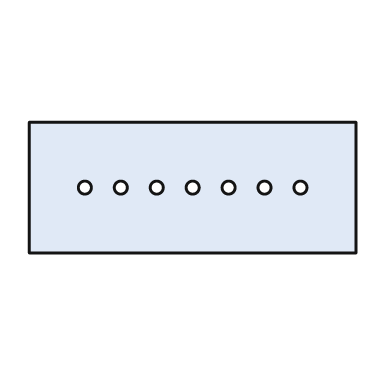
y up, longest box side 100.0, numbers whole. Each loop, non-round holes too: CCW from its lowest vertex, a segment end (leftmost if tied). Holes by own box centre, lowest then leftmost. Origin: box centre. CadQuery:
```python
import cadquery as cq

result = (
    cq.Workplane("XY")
    .moveTo(-50.0, -20.0)
    .lineTo(50.0, -20.0)
    .lineTo(50.0, 20.0)
    .lineTo(-50.0, 20.0)
    .close()
    .moveTo(-33.0, 0.0)
    .circle(2.0)
    .moveTo(-22.0, 0.0)
    .circle(2.0)
    .moveTo(-11.0, 0.0)
    .circle(2.0)
    .moveTo(0.0, 0.0)
    .circle(2.0)
    .moveTo(11.0, 0.0)
    .circle(2.0)
    .moveTo(22.0, 0.0)
    .circle(2.0)
    .moveTo(33.0, 0.0)
    .circle(2.0)
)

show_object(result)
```